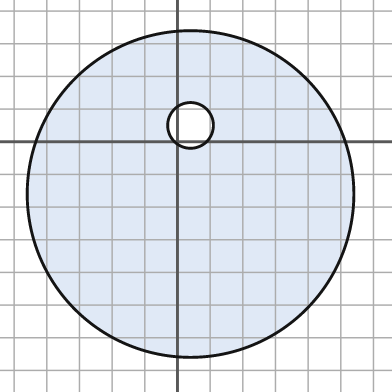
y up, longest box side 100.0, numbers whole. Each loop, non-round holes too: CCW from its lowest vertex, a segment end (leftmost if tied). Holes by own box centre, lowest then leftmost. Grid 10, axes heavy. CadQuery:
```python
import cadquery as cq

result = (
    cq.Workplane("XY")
    .moveTo(4.0, -16.0)
    .circle(50.0)
    .moveTo(4.0, 5.0)
    .circle(7.0)
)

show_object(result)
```